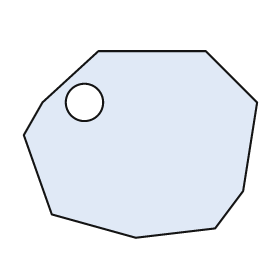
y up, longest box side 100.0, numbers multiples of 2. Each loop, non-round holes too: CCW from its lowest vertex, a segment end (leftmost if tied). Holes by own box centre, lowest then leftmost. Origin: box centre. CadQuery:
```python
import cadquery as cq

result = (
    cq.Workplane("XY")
    .moveTo(-2.0, -40.0)
    .lineTo(32.0, -36.0)
    .lineTo(44.0, -20.0)
    .lineTo(50.0, 18.0)
    .lineTo(28.0, 40.0)
    .lineTo(-18.0, 40.0)
    .lineTo(-42.0, 18.0)
    .lineTo(-50.0, 4.0)
    .lineTo(-38.0, -30.0)
    .close()
    .moveTo(-24.0, 18.0)
    .circle(8.0)
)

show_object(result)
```